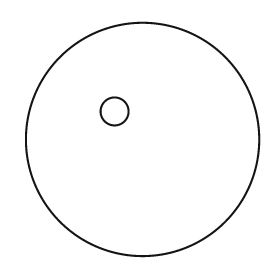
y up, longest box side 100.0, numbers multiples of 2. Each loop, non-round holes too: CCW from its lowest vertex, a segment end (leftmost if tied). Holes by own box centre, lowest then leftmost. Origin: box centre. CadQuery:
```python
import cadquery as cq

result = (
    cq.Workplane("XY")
    .moveTo(0.0, 0.0)
    .circle(50.0)
    .moveTo(-12.0, 12.0)
    .circle(6.0)
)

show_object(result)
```